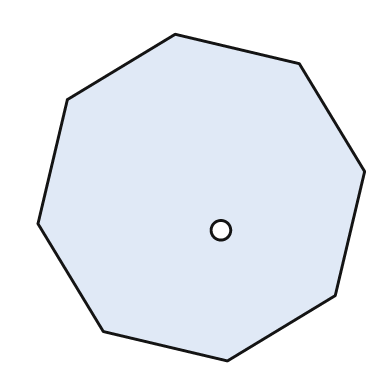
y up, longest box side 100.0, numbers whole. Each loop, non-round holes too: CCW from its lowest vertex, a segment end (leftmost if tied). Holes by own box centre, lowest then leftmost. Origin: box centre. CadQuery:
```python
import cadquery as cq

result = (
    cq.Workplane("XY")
    .moveTo(8.0, -50.0)
    .lineTo(41.0, -30.0)
    .lineTo(50.0, 8.0)
    .lineTo(30.0, 41.0)
    .lineTo(-8.0, 50.0)
    .lineTo(-41.0, 30.0)
    .lineTo(-50.0, -8.0)
    .lineTo(-30.0, -41.0)
    .close()
    .moveTo(6.0, -10.0)
    .circle(3.0)
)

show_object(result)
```